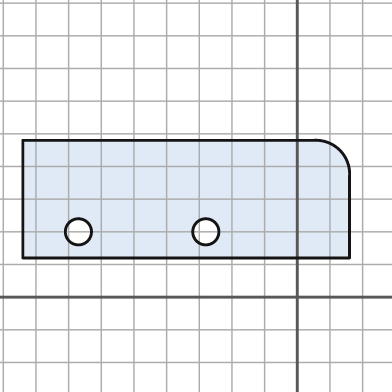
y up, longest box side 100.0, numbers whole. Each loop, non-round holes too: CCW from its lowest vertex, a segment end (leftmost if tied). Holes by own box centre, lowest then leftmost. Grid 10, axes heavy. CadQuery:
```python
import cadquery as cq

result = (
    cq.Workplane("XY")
    .moveTo(-84.0, 12.0)
    .lineTo(16.0, 12.0)
    .lineTo(16.0, 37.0)
    .threePointArc((13.0, 45.0), (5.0, 48.0))
    .lineTo(-84.0, 48.0)
    .close()
    .moveTo(-67.0, 20.0)
    .circle(4.0)
    .moveTo(-28.0, 20.0)
    .circle(4.0)
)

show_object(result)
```